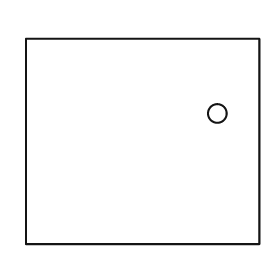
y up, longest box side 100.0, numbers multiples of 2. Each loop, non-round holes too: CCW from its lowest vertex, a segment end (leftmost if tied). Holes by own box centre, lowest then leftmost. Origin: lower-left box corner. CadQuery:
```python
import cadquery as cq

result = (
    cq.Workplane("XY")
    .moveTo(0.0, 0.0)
    .lineTo(100.0, 0.0)
    .lineTo(100.0, 88.0)
    .lineTo(0.0, 88.0)
    .close()
    .moveTo(82.0, 56.0)
    .circle(4.0)
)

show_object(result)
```